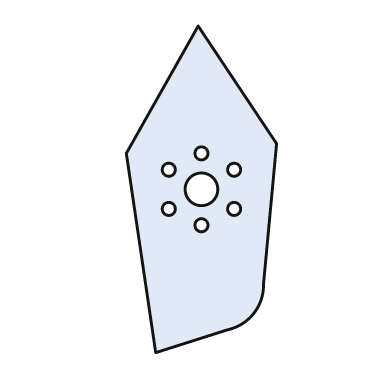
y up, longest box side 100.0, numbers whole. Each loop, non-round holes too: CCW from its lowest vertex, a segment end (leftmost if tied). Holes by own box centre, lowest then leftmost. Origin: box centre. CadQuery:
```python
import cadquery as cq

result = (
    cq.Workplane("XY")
    .moveTo(-14.0, -50.0)
    .lineTo(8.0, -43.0)
    .threePointArc((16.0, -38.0), (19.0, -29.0))
    .lineTo(23.0, 14.0)
    .lineTo(-1.0, 50.0)
    .lineTo(-23.0, 11.0)
    .close()
    .moveTo(0.0, -11.0)
    .circle(2.0)
    .moveTo(-10.0, -6.0)
    .circle(2.0)
    .moveTo(10.0, -6.0)
    .circle(2.0)
    .moveTo(0.0, 0.0)
    .circle(5.0)
    .moveTo(-10.0, 6.0)
    .circle(2.0)
    .moveTo(10.0, 6.0)
    .circle(2.0)
    .moveTo(0.0, 11.0)
    .circle(2.0)
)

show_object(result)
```